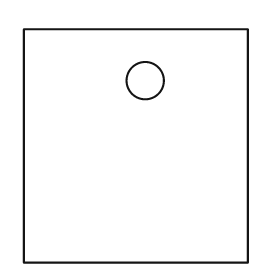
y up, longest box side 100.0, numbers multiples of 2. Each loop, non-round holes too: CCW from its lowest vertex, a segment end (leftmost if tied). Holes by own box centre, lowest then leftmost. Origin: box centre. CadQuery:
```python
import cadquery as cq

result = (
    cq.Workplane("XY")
    .moveTo(-48.0, -50.0)
    .lineTo(48.0, -50.0)
    .lineTo(48.0, 50.0)
    .lineTo(-48.0, 50.0)
    .close()
    .moveTo(4.0, 28.0)
    .circle(8.0)
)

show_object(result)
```